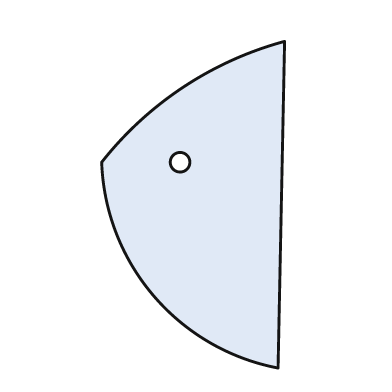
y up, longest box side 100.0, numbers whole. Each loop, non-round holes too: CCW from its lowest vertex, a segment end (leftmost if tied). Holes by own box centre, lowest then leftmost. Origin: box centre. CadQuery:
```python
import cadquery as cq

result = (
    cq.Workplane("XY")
    .moveTo(26.0, -50.0)
    .lineTo(28.0, 50.0)
    .threePointArc((-3.0, 36.0), (-28.0, 13.0))
    .threePointArc((-12.0, -28.0), (26.0, -50.0))
    .close()
    .moveTo(-4.0, 13.0)
    .circle(3.0)
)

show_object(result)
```